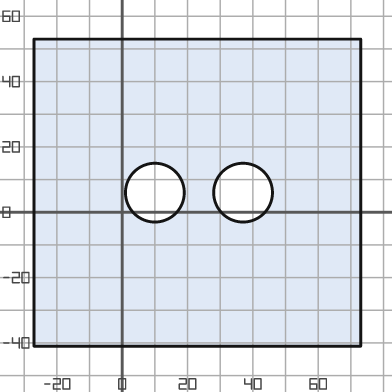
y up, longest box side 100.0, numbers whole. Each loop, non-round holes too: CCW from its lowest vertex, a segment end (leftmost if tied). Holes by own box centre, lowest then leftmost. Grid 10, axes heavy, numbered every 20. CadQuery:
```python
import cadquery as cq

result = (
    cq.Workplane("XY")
    .moveTo(-27.0, -41.0)
    .lineTo(73.0, -41.0)
    .lineTo(73.0, 53.0)
    .lineTo(-27.0, 53.0)
    .close()
    .moveTo(10.0, 6.0)
    .circle(9.0)
    .moveTo(37.0, 6.0)
    .circle(9.0)
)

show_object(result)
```